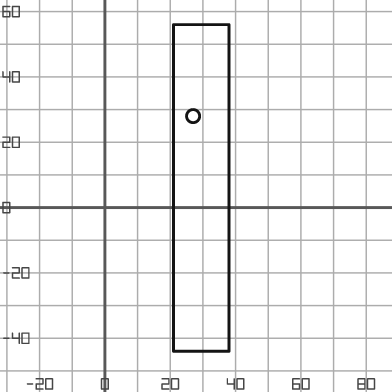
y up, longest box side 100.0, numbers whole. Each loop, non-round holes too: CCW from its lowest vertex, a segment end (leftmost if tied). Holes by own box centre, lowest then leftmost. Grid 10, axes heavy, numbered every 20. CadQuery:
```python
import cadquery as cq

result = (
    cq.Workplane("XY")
    .moveTo(21.0, -44.0)
    .lineTo(38.0, -44.0)
    .lineTo(38.0, 56.0)
    .lineTo(21.0, 56.0)
    .close()
    .moveTo(27.0, 28.0)
    .circle(2.0)
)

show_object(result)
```